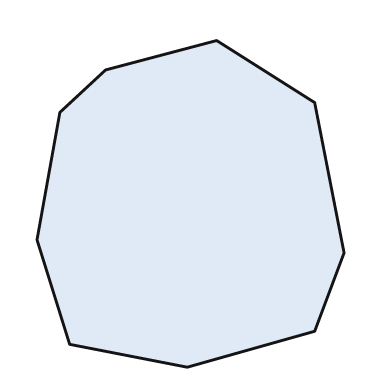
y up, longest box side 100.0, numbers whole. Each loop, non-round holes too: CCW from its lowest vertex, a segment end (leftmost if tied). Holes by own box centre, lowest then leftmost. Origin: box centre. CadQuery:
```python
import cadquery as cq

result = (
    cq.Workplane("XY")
    .moveTo(-1.0, -50.0)
    .lineTo(38.0, -39.0)
    .lineTo(47.0, -15.0)
    .lineTo(38.0, 31.0)
    .lineTo(8.0, 50.0)
    .lineTo(-26.0, 41.0)
    .lineTo(-40.0, 28.0)
    .lineTo(-47.0, -11.0)
    .lineTo(-37.0, -43.0)
    .close()
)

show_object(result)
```